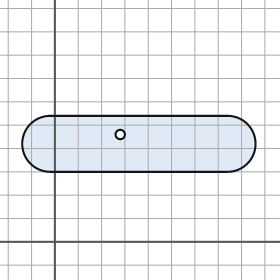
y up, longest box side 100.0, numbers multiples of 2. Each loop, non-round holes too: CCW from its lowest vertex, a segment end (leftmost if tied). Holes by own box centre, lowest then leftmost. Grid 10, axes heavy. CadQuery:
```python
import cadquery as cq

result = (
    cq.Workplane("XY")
    .moveTo(-2.0, 30.0)
    .lineTo(74.0, 30.0)
    .threePointArc((86.0, 42.0), (74.0, 54.0))
    .lineTo(-2.0, 54.0)
    .threePointArc((-14.0, 42.0), (-2.0, 30.0))
    .close()
    .moveTo(28.0, 46.0)
    .circle(2.0)
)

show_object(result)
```